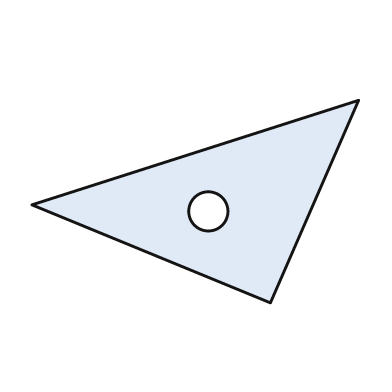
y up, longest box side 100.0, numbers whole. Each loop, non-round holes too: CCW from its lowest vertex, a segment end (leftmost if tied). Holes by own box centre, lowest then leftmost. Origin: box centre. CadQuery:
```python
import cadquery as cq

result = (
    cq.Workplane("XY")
    .moveTo(23.0, -31.0)
    .lineTo(50.0, 31.0)
    .lineTo(-50.0, -1.0)
    .close()
    .moveTo(4.0, -3.0)
    .circle(6.0)
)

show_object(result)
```